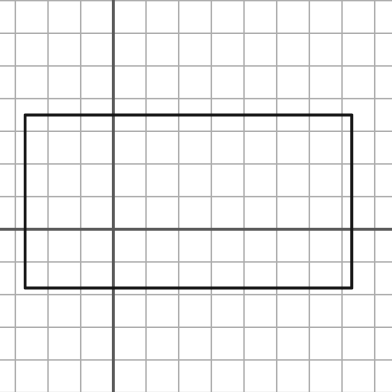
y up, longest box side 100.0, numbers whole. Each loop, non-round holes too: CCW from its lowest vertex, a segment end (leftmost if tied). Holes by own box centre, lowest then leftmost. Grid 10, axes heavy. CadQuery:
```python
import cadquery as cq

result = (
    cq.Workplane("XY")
    .moveTo(-27.0, -18.0)
    .lineTo(73.0, -18.0)
    .lineTo(73.0, 35.0)
    .lineTo(-27.0, 35.0)
    .close()
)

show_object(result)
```